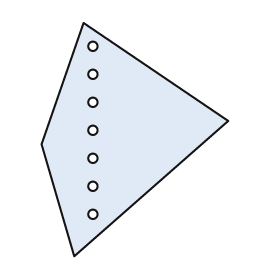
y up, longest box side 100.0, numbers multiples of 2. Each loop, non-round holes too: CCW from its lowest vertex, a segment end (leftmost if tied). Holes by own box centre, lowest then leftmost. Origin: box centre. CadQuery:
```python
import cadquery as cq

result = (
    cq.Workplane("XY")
    .moveTo(-26.0, -50.0)
    .lineTo(40.0, 8.0)
    .lineTo(-22.0, 50.0)
    .lineTo(-40.0, -2.0)
    .close()
    .moveTo(-18.0, -32.0)
    .circle(2.0)
    .moveTo(-18.0, -20.0)
    .circle(2.0)
    .moveTo(-18.0, -8.0)
    .circle(2.0)
    .moveTo(-18.0, 4.0)
    .circle(2.0)
    .moveTo(-18.0, 16.0)
    .circle(2.0)
    .moveTo(-18.0, 28.0)
    .circle(2.0)
    .moveTo(-18.0, 40.0)
    .circle(2.0)
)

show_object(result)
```